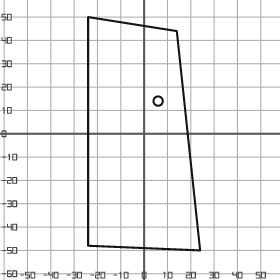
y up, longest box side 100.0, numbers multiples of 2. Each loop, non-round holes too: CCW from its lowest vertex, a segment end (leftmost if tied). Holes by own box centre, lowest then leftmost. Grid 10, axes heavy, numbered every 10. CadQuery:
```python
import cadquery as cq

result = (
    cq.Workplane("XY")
    .moveTo(24.0, -50.0)
    .lineTo(14.0, 44.0)
    .lineTo(-24.0, 50.0)
    .lineTo(-24.0, -48.0)
    .close()
    .moveTo(6.0, 14.0)
    .circle(2.0)
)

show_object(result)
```